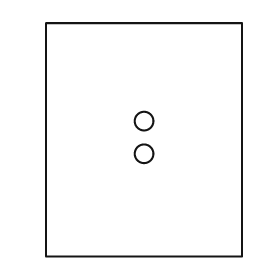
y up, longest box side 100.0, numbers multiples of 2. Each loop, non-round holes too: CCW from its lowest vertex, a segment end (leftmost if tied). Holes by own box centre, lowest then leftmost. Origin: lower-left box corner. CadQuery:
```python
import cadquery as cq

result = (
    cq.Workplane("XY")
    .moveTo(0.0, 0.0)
    .lineTo(84.0, 0.0)
    .lineTo(84.0, 100.0)
    .lineTo(0.0, 100.0)
    .close()
    .moveTo(42.0, 44.0)
    .circle(4.0)
    .moveTo(42.0, 58.0)
    .circle(4.0)
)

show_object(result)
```